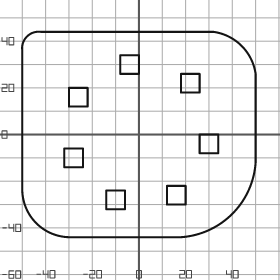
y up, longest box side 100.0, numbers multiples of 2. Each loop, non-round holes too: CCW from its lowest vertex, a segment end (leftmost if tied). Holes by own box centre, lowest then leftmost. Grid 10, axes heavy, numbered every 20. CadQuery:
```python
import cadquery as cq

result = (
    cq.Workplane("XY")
    .moveTo(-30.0, -44.0)
    .lineTo(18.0, -44.0)
    .threePointArc((40.0, -34.0), (50.0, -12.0))
    .lineTo(50.0, 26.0)
    .threePointArc((44.0, 38.0), (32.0, 44.0))
    .lineTo(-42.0, 44.0)
    .threePointArc((-48.0, 42.0), (-50.0, 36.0))
    .lineTo(-50.0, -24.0)
    .threePointArc((-44.0, -38.0), (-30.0, -44.0))
    .close()
    .moveTo(-14.0, -32.0)
    .lineTo(-6.0, -32.0)
    .lineTo(-6.0, -24.0)
    .lineTo(-14.0, -24.0)
    .close()
    .moveTo(12.0, -30.0)
    .lineTo(20.0, -30.0)
    .lineTo(20.0, -22.0)
    .lineTo(12.0, -22.0)
    .close()
    .moveTo(-32.0, -14.0)
    .lineTo(-24.0, -14.0)
    .lineTo(-24.0, -6.0)
    .lineTo(-32.0, -6.0)
    .close()
    .moveTo(26.0, -8.0)
    .lineTo(34.0, -8.0)
    .lineTo(34.0, 0.0)
    .lineTo(26.0, 0.0)
    .close()
    .moveTo(-30.0, 12.0)
    .lineTo(-22.0, 12.0)
    .lineTo(-22.0, 20.0)
    .lineTo(-30.0, 20.0)
    .close()
    .moveTo(18.0, 18.0)
    .lineTo(26.0, 18.0)
    .lineTo(26.0, 26.0)
    .lineTo(18.0, 26.0)
    .close()
    .moveTo(-8.0, 26.0)
    .lineTo(0.0, 26.0)
    .lineTo(0.0, 34.0)
    .lineTo(-8.0, 34.0)
    .close()
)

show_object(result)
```